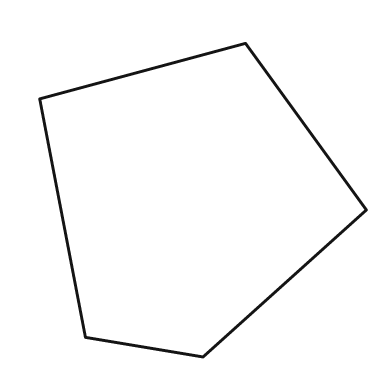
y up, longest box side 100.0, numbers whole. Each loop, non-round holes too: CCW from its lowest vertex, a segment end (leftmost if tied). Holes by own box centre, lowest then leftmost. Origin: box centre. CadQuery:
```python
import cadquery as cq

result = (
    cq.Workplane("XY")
    .moveTo(0.0, -48.0)
    .lineTo(50.0, -3.0)
    .lineTo(13.0, 48.0)
    .lineTo(-50.0, 31.0)
    .lineTo(-36.0, -42.0)
    .close()
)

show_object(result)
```